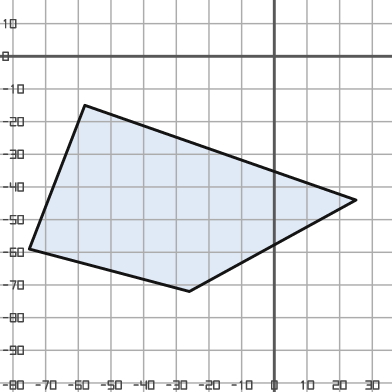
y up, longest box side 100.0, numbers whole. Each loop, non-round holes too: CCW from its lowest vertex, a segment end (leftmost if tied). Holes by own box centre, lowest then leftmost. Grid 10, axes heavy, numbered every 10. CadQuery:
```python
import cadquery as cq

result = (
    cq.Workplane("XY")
    .moveTo(-26.0, -72.0)
    .lineTo(25.0, -44.0)
    .lineTo(-58.0, -15.0)
    .lineTo(-75.0, -59.0)
    .close()
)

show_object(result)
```